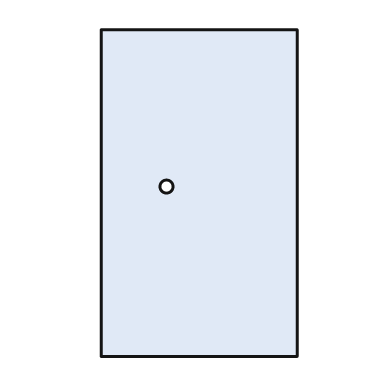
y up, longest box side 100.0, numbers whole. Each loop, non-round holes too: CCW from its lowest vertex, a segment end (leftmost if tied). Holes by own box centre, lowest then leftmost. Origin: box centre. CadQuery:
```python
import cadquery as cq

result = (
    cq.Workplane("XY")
    .moveTo(-30.0, -50.0)
    .lineTo(30.0, -50.0)
    .lineTo(30.0, 50.0)
    .lineTo(-30.0, 50.0)
    .close()
    .moveTo(-10.0, 2.0)
    .circle(2.0)
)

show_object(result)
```